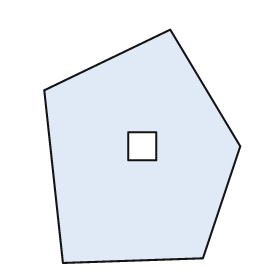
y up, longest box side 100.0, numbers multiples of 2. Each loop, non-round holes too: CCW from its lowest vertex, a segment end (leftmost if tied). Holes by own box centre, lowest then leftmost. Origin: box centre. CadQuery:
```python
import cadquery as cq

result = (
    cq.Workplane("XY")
    .moveTo(-34.0, -50.0)
    .lineTo(26.0, -48.0)
    .lineTo(42.0, 0.0)
    .lineTo(12.0, 50.0)
    .lineTo(-42.0, 24.0)
    .close()
    .moveTo(-6.0, -6.0)
    .lineTo(6.0, -6.0)
    .lineTo(6.0, 6.0)
    .lineTo(-6.0, 6.0)
    .close()
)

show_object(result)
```